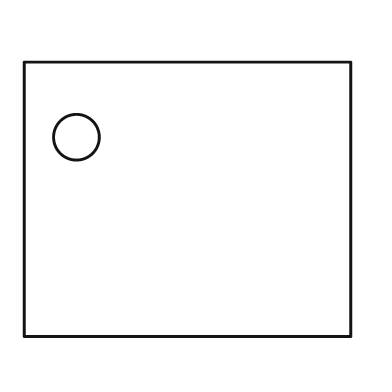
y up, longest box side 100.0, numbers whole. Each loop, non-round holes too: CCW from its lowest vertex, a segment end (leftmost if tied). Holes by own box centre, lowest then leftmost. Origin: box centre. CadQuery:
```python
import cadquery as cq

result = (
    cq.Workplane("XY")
    .moveTo(-50.0, -42.0)
    .lineTo(50.0, -42.0)
    .lineTo(50.0, 42.0)
    .lineTo(-50.0, 42.0)
    .close()
    .moveTo(-34.0, 19.0)
    .circle(7.0)
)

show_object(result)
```